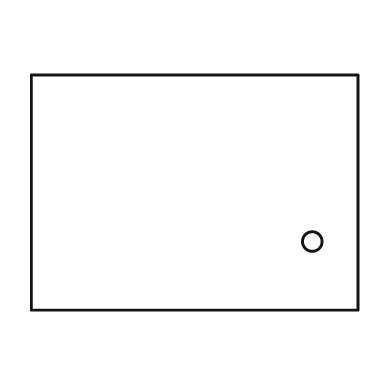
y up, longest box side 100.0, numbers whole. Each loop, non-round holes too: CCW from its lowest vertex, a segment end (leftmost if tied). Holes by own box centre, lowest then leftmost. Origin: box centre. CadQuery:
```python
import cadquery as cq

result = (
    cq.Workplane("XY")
    .moveTo(-50.0, -36.0)
    .lineTo(50.0, -36.0)
    .lineTo(50.0, 36.0)
    .lineTo(-50.0, 36.0)
    .close()
    .moveTo(36.0, -15.0)
    .circle(3.0)
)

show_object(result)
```